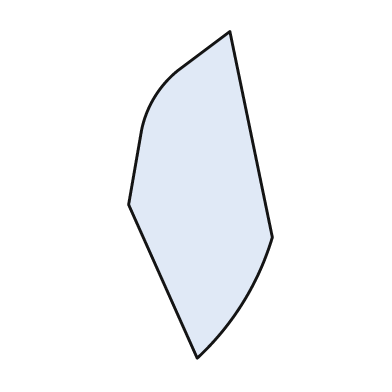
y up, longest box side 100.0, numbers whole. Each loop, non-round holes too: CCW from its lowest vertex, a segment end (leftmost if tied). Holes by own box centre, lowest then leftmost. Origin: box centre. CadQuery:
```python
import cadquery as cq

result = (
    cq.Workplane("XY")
    .moveTo(-1.0, -50.0)
    .threePointArc((13.0, -33.0), (22.0, -13.0))
    .lineTo(9.0, 50.0)
    .lineTo(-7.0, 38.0)
    .threePointArc((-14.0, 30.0), (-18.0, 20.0))
    .lineTo(-22.0, -3.0)
    .close()
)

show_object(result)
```